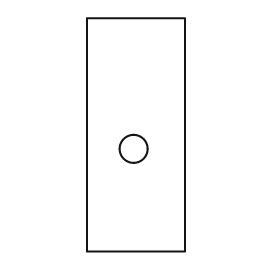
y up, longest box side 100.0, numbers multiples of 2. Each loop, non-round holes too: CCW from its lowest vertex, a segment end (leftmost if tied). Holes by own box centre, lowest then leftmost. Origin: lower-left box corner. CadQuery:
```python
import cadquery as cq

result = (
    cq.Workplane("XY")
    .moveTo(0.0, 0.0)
    .lineTo(42.0, 0.0)
    .lineTo(42.0, 100.0)
    .lineTo(0.0, 100.0)
    .close()
    .moveTo(20.0, 44.0)
    .circle(6.0)
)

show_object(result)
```